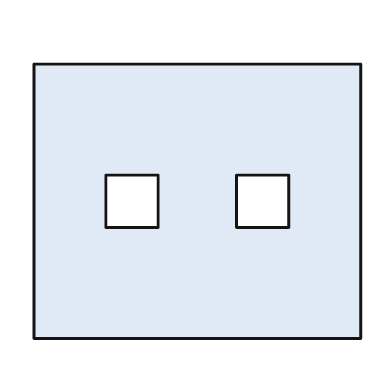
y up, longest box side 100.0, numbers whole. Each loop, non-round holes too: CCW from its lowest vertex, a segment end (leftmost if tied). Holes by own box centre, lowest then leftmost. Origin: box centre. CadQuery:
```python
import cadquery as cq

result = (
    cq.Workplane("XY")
    .moveTo(-50.0, -42.0)
    .lineTo(50.0, -42.0)
    .lineTo(50.0, 42.0)
    .lineTo(-50.0, 42.0)
    .close()
    .moveTo(-28.0, -8.0)
    .lineTo(-12.0, -8.0)
    .lineTo(-12.0, 8.0)
    .lineTo(-28.0, 8.0)
    .close()
    .moveTo(12.0, -8.0)
    .lineTo(28.0, -8.0)
    .lineTo(28.0, 8.0)
    .lineTo(12.0, 8.0)
    .close()
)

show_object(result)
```